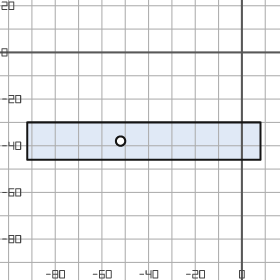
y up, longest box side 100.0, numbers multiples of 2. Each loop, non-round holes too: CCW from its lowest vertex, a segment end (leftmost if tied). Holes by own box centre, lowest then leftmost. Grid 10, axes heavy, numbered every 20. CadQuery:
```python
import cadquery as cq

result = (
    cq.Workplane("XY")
    .moveTo(-92.0, -46.0)
    .lineTo(8.0, -46.0)
    .lineTo(8.0, -30.0)
    .lineTo(-92.0, -30.0)
    .close()
    .moveTo(-52.0, -38.0)
    .circle(2.0)
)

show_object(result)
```